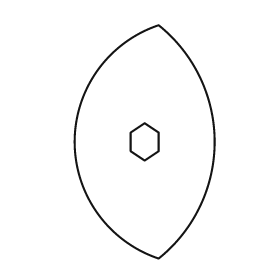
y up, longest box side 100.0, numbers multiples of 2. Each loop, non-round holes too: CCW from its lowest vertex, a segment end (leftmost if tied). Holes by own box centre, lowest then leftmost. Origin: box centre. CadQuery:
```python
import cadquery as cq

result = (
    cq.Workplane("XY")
    .moveTo(6.0, -50.0)
    .threePointArc((30.0, 0.0), (6.0, 50.0))
    .threePointArc((-30.0, 0.0), (6.0, -50.0))
    .close()
    .moveTo(0.0, -8.0)
    .lineTo(6.0, -4.0)
    .lineTo(6.0, 4.0)
    .lineTo(0.0, 8.0)
    .lineTo(-6.0, 4.0)
    .lineTo(-6.0, -4.0)
    .close()
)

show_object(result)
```